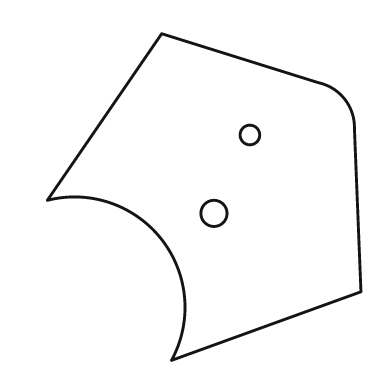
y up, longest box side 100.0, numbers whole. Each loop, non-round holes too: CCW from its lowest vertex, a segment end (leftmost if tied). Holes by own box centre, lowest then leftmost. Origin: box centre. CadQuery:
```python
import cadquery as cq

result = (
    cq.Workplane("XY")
    .moveTo(-10.0, -50.0)
    .lineTo(48.0, -29.0)
    .lineTo(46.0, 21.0)
    .threePointArc((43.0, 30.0), (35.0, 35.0))
    .lineTo(-13.0, 50.0)
    .lineTo(-48.0, -1.0)
    .threePointArc((-13.0, -13.0), (-10.0, -50.0))
    .close()
    .moveTo(3.0, -5.0)
    .circle(4.0)
    .moveTo(14.0, 19.0)
    .circle(3.0)
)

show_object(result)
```